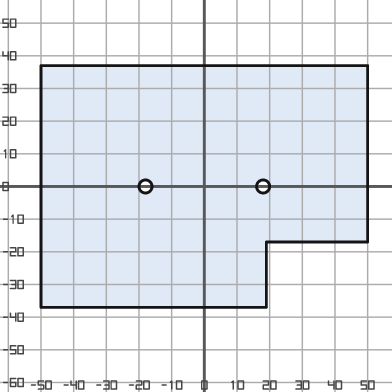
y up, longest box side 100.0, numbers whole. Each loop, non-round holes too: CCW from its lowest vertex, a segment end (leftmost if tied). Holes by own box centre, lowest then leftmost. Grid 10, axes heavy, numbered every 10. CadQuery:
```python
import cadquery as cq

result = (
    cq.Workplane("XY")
    .moveTo(-50.0, -37.0)
    .lineTo(19.0, -37.0)
    .lineTo(19.0, -17.0)
    .lineTo(50.0, -17.0)
    .lineTo(50.0, 37.0)
    .lineTo(-50.0, 37.0)
    .close()
    .moveTo(-18.0, 0.0)
    .circle(2.0)
    .moveTo(18.0, 0.0)
    .circle(2.0)
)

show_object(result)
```